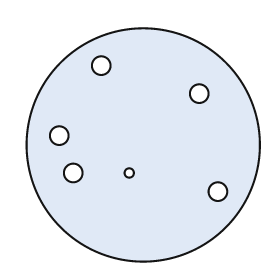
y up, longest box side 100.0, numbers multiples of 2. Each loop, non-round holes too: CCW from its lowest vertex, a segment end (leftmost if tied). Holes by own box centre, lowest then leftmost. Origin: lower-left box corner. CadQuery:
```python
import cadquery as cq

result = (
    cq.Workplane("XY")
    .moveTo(50.0, 50.0)
    .circle(50.0)
    .moveTo(82.0, 30.0)
    .circle(4.0)
    .moveTo(20.0, 38.0)
    .circle(4.0)
    .moveTo(44.0, 38.0)
    .circle(2.0)
    .moveTo(14.0, 54.0)
    .circle(4.0)
    .moveTo(74.0, 72.0)
    .circle(4.0)
    .moveTo(32.0, 84.0)
    .circle(4.0)
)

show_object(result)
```